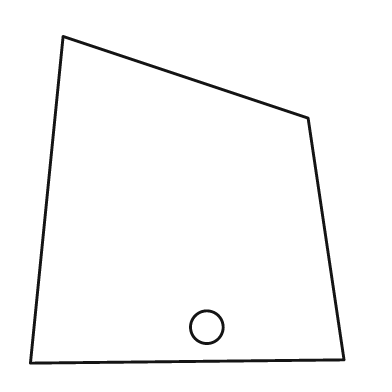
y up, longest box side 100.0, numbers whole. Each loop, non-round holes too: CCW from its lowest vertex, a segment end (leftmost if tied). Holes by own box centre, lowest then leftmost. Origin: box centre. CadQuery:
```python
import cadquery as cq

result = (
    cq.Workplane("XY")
    .moveTo(-48.0, -50.0)
    .lineTo(48.0, -49.0)
    .lineTo(37.0, 25.0)
    .lineTo(-38.0, 50.0)
    .close()
    .moveTo(6.0, -39.0)
    .circle(5.0)
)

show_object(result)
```